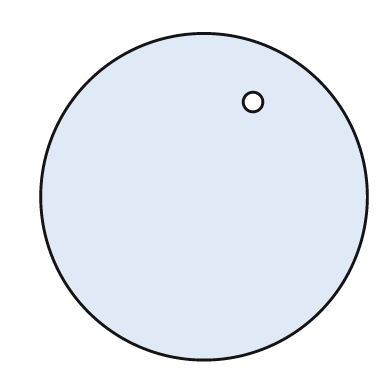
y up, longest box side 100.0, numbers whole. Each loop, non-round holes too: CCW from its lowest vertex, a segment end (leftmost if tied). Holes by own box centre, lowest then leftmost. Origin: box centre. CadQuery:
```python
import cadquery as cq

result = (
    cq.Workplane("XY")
    .moveTo(0.0, 0.0)
    .circle(50.0)
    .moveTo(15.0, 29.0)
    .circle(3.0)
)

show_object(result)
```